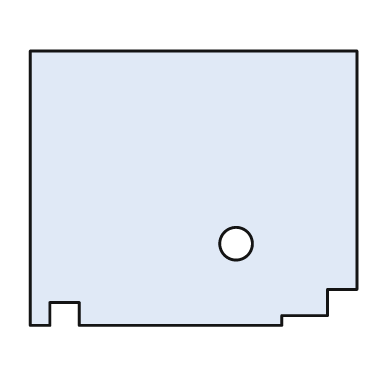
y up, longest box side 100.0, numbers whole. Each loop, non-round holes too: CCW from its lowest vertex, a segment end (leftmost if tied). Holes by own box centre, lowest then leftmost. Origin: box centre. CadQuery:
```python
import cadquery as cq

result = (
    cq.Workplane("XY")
    .moveTo(-50.0, -42.0)
    .lineTo(-44.0, -42.0)
    .lineTo(-44.0, -35.0)
    .lineTo(-35.0, -35.0)
    .lineTo(-35.0, -42.0)
    .lineTo(27.0, -42.0)
    .lineTo(27.0, -39.0)
    .lineTo(41.0, -39.0)
    .lineTo(41.0, -31.0)
    .lineTo(50.0, -31.0)
    .lineTo(50.0, 42.0)
    .lineTo(-50.0, 42.0)
    .close()
    .moveTo(13.0, -17.0)
    .circle(5.0)
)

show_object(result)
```